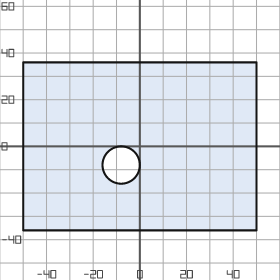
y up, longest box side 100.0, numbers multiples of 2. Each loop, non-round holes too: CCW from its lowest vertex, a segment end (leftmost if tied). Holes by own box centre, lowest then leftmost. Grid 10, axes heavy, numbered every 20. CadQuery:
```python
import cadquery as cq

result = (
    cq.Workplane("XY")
    .moveTo(-50.0, -36.0)
    .lineTo(50.0, -36.0)
    .lineTo(50.0, 36.0)
    .lineTo(-50.0, 36.0)
    .close()
    .moveTo(-8.0, -8.0)
    .circle(8.0)
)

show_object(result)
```